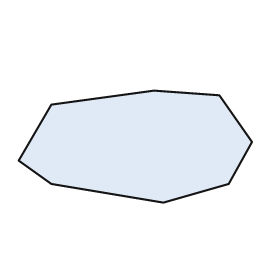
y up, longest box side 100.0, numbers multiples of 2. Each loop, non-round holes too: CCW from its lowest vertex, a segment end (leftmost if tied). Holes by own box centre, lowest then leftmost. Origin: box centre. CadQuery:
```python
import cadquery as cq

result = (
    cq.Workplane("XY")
    .moveTo(12.0, -24.0)
    .lineTo(40.0, -16.0)
    .lineTo(50.0, 2.0)
    .lineTo(36.0, 22.0)
    .lineTo(8.0, 24.0)
    .lineTo(-36.0, 18.0)
    .lineTo(-50.0, -6.0)
    .lineTo(-36.0, -16.0)
    .close()
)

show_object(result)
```